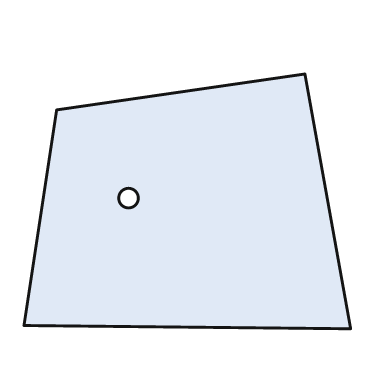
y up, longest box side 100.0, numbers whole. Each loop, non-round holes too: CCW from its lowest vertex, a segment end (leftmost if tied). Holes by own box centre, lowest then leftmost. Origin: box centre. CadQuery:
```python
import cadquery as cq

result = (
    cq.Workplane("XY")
    .moveTo(50.0, -39.0)
    .lineTo(36.0, 39.0)
    .lineTo(-40.0, 28.0)
    .lineTo(-50.0, -38.0)
    .close()
    .moveTo(-18.0, 1.0)
    .circle(3.0)
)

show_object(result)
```